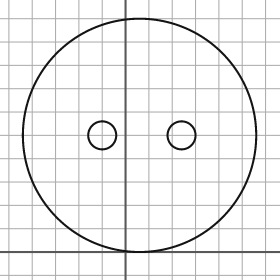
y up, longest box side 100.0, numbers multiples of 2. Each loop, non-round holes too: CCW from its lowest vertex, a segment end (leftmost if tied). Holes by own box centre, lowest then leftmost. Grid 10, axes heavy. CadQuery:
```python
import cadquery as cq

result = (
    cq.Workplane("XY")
    .moveTo(6.0, 50.0)
    .circle(50.0)
    .moveTo(-10.0, 50.0)
    .circle(6.0)
    .moveTo(24.0, 50.0)
    .circle(6.0)
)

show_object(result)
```